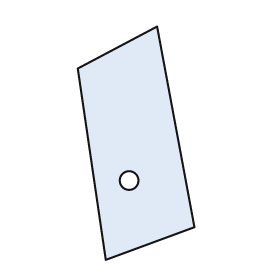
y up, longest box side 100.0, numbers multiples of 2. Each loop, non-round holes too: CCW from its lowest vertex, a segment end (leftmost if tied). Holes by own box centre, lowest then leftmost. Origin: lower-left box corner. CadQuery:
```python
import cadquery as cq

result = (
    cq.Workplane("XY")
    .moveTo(12.0, 0.0)
    .lineTo(50.0, 14.0)
    .lineTo(34.0, 100.0)
    .lineTo(0.0, 82.0)
    .close()
    .moveTo(22.0, 34.0)
    .circle(4.0)
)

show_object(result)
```